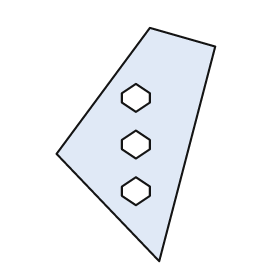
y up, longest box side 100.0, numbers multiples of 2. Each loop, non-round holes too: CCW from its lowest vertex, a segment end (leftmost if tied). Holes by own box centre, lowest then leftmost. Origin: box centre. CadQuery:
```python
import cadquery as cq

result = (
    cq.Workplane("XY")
    .moveTo(10.0, -50.0)
    .lineTo(34.0, 42.0)
    .lineTo(6.0, 50.0)
    .lineTo(-34.0, -4.0)
    .close()
    .moveTo(0.0, -26.0)
    .lineTo(6.0, -22.0)
    .lineTo(6.0, -18.0)
    .lineTo(0.0, -14.0)
    .lineTo(-6.0, -18.0)
    .lineTo(-6.0, -22.0)
    .close()
    .moveTo(0.0, -6.0)
    .lineTo(6.0, -2.0)
    .lineTo(6.0, 2.0)
    .lineTo(0.0, 6.0)
    .lineTo(-6.0, 2.0)
    .lineTo(-6.0, -2.0)
    .close()
    .moveTo(0.0, 14.0)
    .lineTo(6.0, 18.0)
    .lineTo(6.0, 22.0)
    .lineTo(0.0, 26.0)
    .lineTo(-6.0, 22.0)
    .lineTo(-6.0, 18.0)
    .close()
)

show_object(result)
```